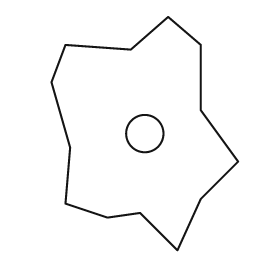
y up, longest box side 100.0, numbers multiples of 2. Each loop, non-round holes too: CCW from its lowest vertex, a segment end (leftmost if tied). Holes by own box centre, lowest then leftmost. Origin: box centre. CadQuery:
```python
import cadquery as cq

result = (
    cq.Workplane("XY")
    .moveTo(14.0, -50.0)
    .lineTo(24.0, -28.0)
    .lineTo(40.0, -12.0)
    .lineTo(24.0, 10.0)
    .lineTo(24.0, 38.0)
    .lineTo(10.0, 50.0)
    .lineTo(-6.0, 36.0)
    .lineTo(-34.0, 38.0)
    .lineTo(-40.0, 22.0)
    .lineTo(-32.0, -6.0)
    .lineTo(-34.0, -30.0)
    .lineTo(-16.0, -36.0)
    .lineTo(-2.0, -34.0)
    .close()
    .moveTo(0.0, 0.0)
    .circle(8.0)
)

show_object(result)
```